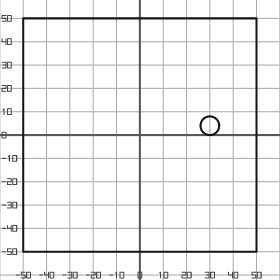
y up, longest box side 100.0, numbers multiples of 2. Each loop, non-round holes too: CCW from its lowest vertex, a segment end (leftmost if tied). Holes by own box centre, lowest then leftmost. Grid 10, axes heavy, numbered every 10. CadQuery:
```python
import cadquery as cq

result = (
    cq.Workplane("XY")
    .moveTo(-50.0, -50.0)
    .lineTo(50.0, -50.0)
    .lineTo(50.0, 50.0)
    .lineTo(-50.0, 50.0)
    .close()
    .moveTo(30.0, 4.0)
    .circle(4.0)
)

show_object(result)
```